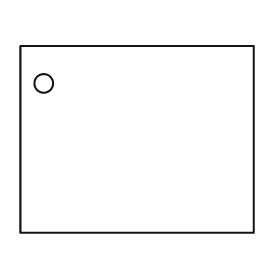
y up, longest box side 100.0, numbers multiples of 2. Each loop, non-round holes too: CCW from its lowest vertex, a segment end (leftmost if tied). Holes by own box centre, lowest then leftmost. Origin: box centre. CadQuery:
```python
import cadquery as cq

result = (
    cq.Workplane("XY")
    .moveTo(-50.0, -40.0)
    .lineTo(50.0, -40.0)
    .lineTo(50.0, 40.0)
    .lineTo(-50.0, 40.0)
    .close()
    .moveTo(-40.0, 24.0)
    .circle(4.0)
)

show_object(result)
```